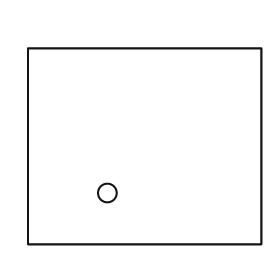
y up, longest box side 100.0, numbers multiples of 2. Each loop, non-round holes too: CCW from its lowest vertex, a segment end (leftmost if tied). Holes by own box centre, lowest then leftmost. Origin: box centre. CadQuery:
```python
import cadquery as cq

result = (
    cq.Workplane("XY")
    .moveTo(-50.0, -42.0)
    .lineTo(50.0, -42.0)
    .lineTo(50.0, 42.0)
    .lineTo(-50.0, 42.0)
    .close()
    .moveTo(-16.0, -20.0)
    .circle(4.0)
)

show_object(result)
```